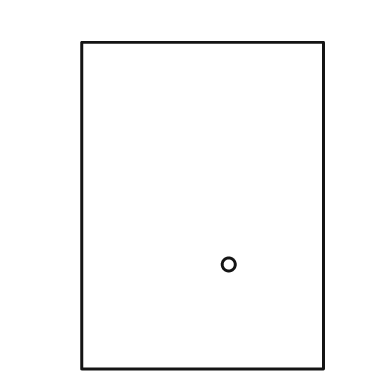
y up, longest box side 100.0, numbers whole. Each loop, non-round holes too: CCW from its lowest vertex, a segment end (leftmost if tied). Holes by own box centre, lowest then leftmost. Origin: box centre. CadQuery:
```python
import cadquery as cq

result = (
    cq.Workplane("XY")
    .moveTo(-37.0, -50.0)
    .lineTo(37.0, -50.0)
    .lineTo(37.0, 50.0)
    .lineTo(-37.0, 50.0)
    .close()
    .moveTo(8.0, -18.0)
    .circle(2.0)
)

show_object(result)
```